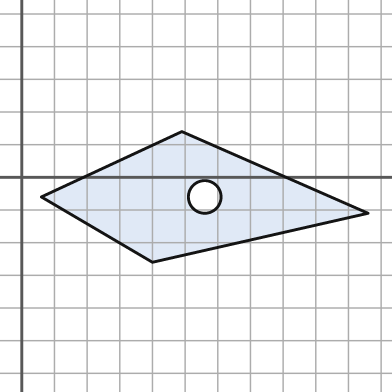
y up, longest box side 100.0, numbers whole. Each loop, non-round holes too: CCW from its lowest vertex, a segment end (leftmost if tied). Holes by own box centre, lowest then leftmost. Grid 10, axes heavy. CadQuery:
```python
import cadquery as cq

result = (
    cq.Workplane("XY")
    .moveTo(40.0, -26.0)
    .lineTo(106.0, -11.0)
    .lineTo(49.0, 14.0)
    .lineTo(6.0, -6.0)
    .close()
    .moveTo(56.0, -6.0)
    .circle(5.0)
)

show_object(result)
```